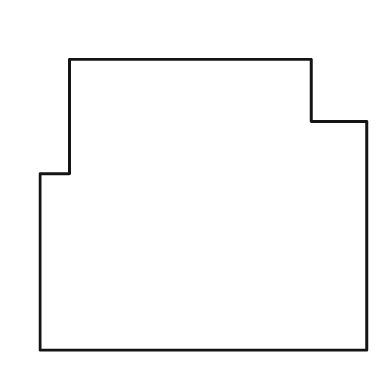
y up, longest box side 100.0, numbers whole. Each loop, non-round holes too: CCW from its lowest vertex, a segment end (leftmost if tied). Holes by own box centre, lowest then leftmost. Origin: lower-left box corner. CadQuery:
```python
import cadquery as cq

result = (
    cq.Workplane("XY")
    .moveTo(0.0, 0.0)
    .lineTo(100.0, 0.0)
    .lineTo(100.0, 70.0)
    .lineTo(83.0, 70.0)
    .lineTo(83.0, 89.0)
    .lineTo(9.0, 89.0)
    .lineTo(9.0, 54.0)
    .lineTo(0.0, 54.0)
    .close()
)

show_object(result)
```